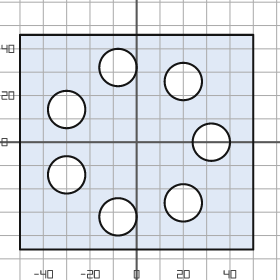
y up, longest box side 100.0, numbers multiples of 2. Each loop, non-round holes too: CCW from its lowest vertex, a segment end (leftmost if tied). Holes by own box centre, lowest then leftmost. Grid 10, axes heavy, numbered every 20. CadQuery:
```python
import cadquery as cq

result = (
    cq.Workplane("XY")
    .moveTo(-50.0, -46.0)
    .lineTo(50.0, -46.0)
    .lineTo(50.0, 46.0)
    .lineTo(-50.0, 46.0)
    .close()
    .moveTo(-8.0, -32.0)
    .circle(8.0)
    .moveTo(20.0, -26.0)
    .circle(8.0)
    .moveTo(-30.0, -14.0)
    .circle(8.0)
    .moveTo(32.0, 0.0)
    .circle(8.0)
    .moveTo(-30.0, 14.0)
    .circle(8.0)
    .moveTo(20.0, 26.0)
    .circle(8.0)
    .moveTo(-8.0, 32.0)
    .circle(8.0)
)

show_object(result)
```